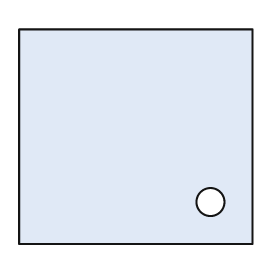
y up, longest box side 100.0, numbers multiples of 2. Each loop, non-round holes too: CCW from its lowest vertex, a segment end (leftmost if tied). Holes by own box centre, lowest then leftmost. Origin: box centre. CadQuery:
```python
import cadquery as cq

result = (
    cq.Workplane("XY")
    .moveTo(-50.0, -46.0)
    .lineTo(50.0, -46.0)
    .lineTo(50.0, 46.0)
    .lineTo(-50.0, 46.0)
    .close()
    .moveTo(32.0, -28.0)
    .circle(6.0)
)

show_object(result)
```